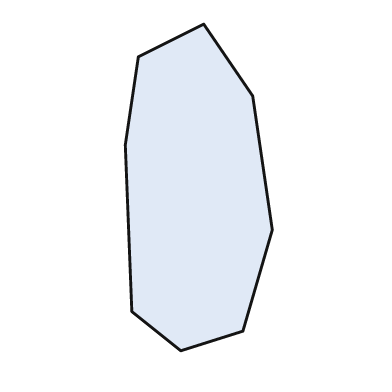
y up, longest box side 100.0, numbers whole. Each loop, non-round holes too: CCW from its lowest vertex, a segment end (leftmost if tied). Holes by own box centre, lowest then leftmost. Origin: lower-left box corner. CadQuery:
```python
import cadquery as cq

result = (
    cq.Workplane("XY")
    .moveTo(17.0, 0.0)
    .lineTo(36.0, 6.0)
    .lineTo(45.0, 37.0)
    .lineTo(39.0, 78.0)
    .lineTo(24.0, 100.0)
    .lineTo(4.0, 90.0)
    .lineTo(0.0, 63.0)
    .lineTo(2.0, 12.0)
    .close()
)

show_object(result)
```